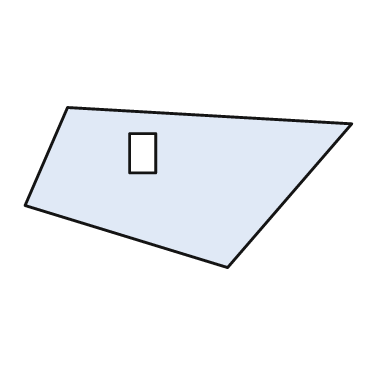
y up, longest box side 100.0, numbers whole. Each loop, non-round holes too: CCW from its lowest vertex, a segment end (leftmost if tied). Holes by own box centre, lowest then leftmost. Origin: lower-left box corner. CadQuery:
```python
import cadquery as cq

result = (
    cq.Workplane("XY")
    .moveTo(62.0, 0.0)
    .lineTo(100.0, 44.0)
    .lineTo(13.0, 49.0)
    .lineTo(0.0, 19.0)
    .close()
    .moveTo(32.0, 29.0)
    .lineTo(40.0, 29.0)
    .lineTo(40.0, 41.0)
    .lineTo(32.0, 41.0)
    .close()
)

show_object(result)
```